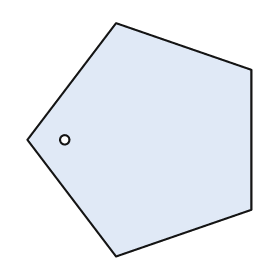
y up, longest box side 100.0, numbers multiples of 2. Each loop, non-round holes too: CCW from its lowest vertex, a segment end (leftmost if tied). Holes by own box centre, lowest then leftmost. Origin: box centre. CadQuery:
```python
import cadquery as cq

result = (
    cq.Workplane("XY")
    .moveTo(-10.0, -50.0)
    .lineTo(48.0, -30.0)
    .lineTo(48.0, 30.0)
    .lineTo(-10.0, 50.0)
    .lineTo(-48.0, 0.0)
    .close()
    .moveTo(-32.0, 0.0)
    .circle(2.0)
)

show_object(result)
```